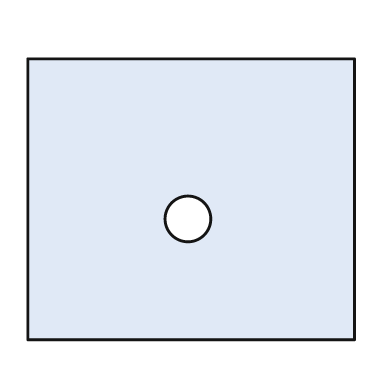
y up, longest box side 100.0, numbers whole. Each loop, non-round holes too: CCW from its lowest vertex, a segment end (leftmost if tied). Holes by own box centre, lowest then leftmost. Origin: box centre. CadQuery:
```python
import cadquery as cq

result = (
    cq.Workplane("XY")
    .moveTo(-50.0, -43.0)
    .lineTo(50.0, -43.0)
    .lineTo(50.0, 43.0)
    .lineTo(-50.0, 43.0)
    .close()
    .moveTo(-1.0, -6.0)
    .circle(7.0)
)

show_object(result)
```